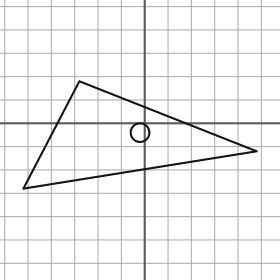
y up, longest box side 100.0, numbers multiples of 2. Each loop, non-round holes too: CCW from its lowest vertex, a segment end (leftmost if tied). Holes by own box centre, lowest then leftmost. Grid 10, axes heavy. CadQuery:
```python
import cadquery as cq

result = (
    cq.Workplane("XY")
    .moveTo(-52.0, -28.0)
    .lineTo(48.0, -12.0)
    .lineTo(-28.0, 18.0)
    .close()
    .moveTo(-2.0, -4.0)
    .circle(4.0)
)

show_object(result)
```